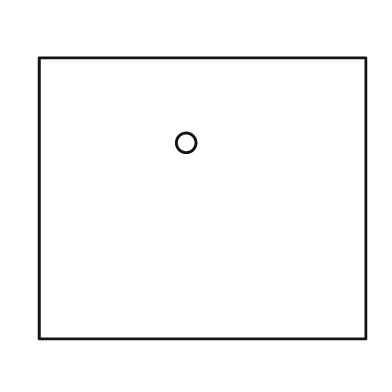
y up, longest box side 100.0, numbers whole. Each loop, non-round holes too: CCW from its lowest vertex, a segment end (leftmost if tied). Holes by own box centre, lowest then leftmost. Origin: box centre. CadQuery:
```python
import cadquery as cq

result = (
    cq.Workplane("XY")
    .moveTo(-50.0, -43.0)
    .lineTo(50.0, -43.0)
    .lineTo(50.0, 43.0)
    .lineTo(-50.0, 43.0)
    .close()
    .moveTo(-5.0, 17.0)
    .circle(3.0)
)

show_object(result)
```